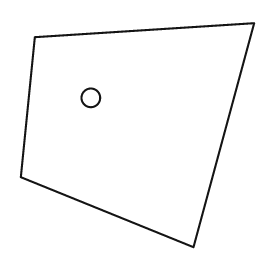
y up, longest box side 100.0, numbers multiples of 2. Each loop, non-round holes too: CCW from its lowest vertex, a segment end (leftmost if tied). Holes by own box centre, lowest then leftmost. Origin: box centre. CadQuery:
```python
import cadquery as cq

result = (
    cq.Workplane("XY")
    .moveTo(24.0, -48.0)
    .lineTo(50.0, 48.0)
    .lineTo(-44.0, 42.0)
    .lineTo(-50.0, -18.0)
    .close()
    .moveTo(-20.0, 16.0)
    .circle(4.0)
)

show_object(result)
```